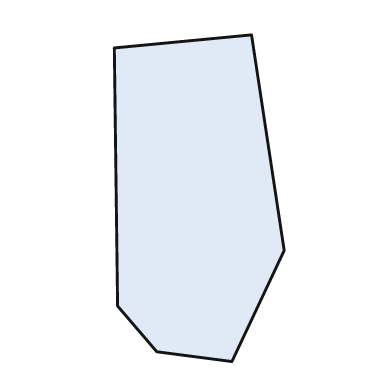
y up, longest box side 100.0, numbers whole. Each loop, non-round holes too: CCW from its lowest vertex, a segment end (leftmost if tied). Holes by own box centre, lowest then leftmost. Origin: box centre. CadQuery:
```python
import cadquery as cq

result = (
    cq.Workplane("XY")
    .moveTo(10.0, -50.0)
    .lineTo(26.0, -16.0)
    .lineTo(16.0, 50.0)
    .lineTo(-26.0, 46.0)
    .lineTo(-25.0, -33.0)
    .lineTo(-13.0, -47.0)
    .close()
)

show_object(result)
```